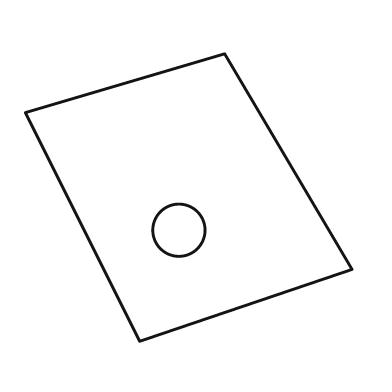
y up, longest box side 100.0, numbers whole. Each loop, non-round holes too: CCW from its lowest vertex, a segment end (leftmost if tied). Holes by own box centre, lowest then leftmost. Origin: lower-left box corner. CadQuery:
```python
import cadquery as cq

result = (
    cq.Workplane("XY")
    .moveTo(35.0, 0.0)
    .lineTo(100.0, 22.0)
    .lineTo(61.0, 88.0)
    .lineTo(0.0, 70.0)
    .close()
    .moveTo(47.0, 34.0)
    .circle(8.0)
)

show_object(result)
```